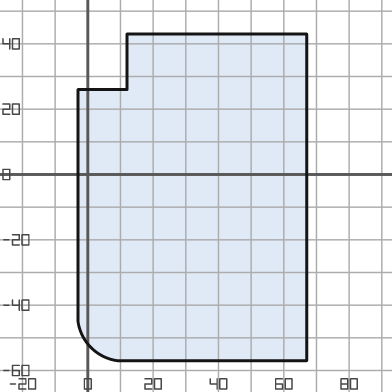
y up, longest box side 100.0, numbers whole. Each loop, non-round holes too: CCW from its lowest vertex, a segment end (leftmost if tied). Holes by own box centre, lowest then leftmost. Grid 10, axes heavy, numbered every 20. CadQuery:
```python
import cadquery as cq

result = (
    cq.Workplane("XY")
    .moveTo(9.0, -57.0)
    .lineTo(67.0, -57.0)
    .lineTo(67.0, 43.0)
    .lineTo(12.0, 43.0)
    .lineTo(12.0, 26.0)
    .lineTo(-3.0, 26.0)
    .lineTo(-3.0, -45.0)
    .threePointArc((1.0, -53.0), (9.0, -57.0))
    .close()
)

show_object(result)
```